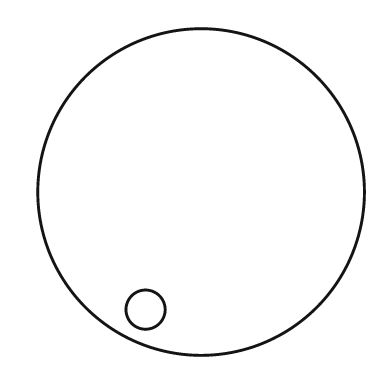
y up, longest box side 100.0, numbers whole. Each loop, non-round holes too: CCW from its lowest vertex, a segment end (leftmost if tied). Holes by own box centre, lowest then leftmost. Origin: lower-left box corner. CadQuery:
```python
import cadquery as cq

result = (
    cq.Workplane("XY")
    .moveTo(50.0, 50.0)
    .circle(50.0)
    .moveTo(33.0, 14.0)
    .circle(6.0)
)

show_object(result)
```